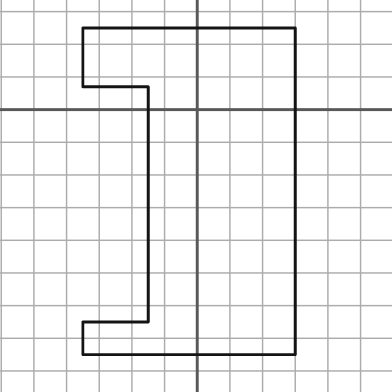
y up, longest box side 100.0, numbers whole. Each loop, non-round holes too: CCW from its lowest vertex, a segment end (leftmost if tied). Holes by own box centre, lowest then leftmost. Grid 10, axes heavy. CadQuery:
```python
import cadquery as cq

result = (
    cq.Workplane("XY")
    .moveTo(-35.0, -75.0)
    .lineTo(30.0, -75.0)
    .lineTo(30.0, 25.0)
    .lineTo(-35.0, 25.0)
    .lineTo(-35.0, 7.0)
    .lineTo(-15.0, 7.0)
    .lineTo(-15.0, -65.0)
    .lineTo(-35.0, -65.0)
    .close()
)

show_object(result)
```